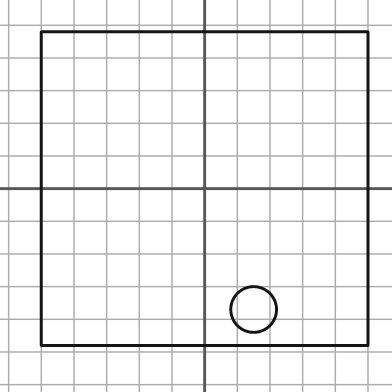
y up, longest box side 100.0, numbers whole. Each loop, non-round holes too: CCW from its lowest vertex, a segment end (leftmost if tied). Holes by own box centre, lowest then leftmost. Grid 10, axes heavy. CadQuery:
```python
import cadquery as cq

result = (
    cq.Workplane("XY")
    .moveTo(-50.0, -48.0)
    .lineTo(50.0, -48.0)
    .lineTo(50.0, 48.0)
    .lineTo(-50.0, 48.0)
    .close()
    .moveTo(15.0, -37.0)
    .circle(7.0)
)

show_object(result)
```